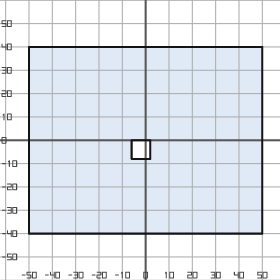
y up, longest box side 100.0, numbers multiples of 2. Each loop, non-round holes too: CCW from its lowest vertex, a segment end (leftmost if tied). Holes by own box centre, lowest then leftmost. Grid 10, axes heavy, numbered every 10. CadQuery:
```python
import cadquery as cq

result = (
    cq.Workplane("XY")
    .moveTo(-50.0, -40.0)
    .lineTo(50.0, -40.0)
    .lineTo(50.0, 40.0)
    .lineTo(-50.0, 40.0)
    .close()
    .moveTo(-6.0, -8.0)
    .lineTo(2.0, -8.0)
    .lineTo(2.0, 0.0)
    .lineTo(-6.0, 0.0)
    .close()
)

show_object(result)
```